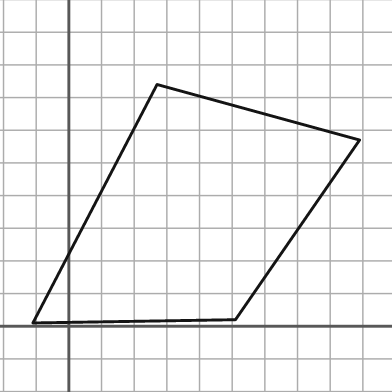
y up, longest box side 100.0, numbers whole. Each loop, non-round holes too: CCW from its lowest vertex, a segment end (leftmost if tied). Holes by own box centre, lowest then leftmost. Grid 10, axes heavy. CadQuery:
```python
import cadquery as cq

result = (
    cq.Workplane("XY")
    .moveTo(-11.0, 1.0)
    .lineTo(51.0, 2.0)
    .lineTo(89.0, 57.0)
    .lineTo(27.0, 74.0)
    .close()
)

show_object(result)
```